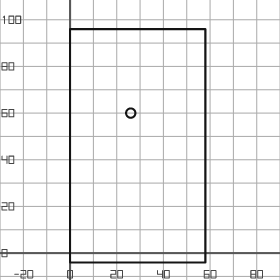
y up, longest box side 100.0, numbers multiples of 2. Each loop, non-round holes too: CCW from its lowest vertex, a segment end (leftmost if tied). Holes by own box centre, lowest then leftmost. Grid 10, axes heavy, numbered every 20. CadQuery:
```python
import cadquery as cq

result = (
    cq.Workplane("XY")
    .moveTo(0.0, -4.0)
    .lineTo(58.0, -4.0)
    .lineTo(58.0, 96.0)
    .lineTo(0.0, 96.0)
    .close()
    .moveTo(26.0, 60.0)
    .circle(2.0)
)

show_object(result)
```